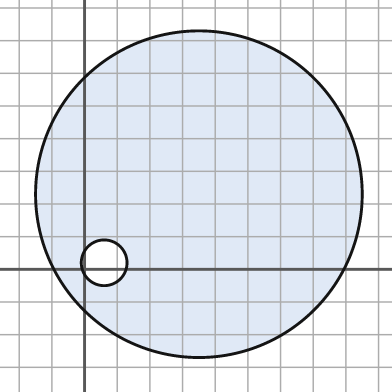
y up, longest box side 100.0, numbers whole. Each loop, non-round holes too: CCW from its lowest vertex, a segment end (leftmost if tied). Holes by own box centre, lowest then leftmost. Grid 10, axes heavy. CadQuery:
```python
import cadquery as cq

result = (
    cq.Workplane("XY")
    .moveTo(35.0, 23.0)
    .circle(50.0)
    .moveTo(6.0, 2.0)
    .circle(7.0)
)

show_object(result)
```